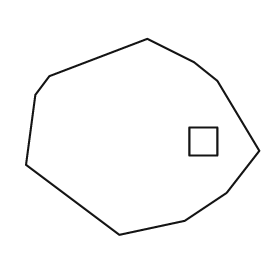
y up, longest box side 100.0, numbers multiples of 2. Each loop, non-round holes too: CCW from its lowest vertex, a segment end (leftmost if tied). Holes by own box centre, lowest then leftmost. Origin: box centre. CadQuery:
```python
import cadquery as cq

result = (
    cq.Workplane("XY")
    .moveTo(-10.0, -42.0)
    .lineTo(18.0, -36.0)
    .lineTo(36.0, -24.0)
    .lineTo(50.0, -6.0)
    .lineTo(32.0, 24.0)
    .lineTo(22.0, 32.0)
    .lineTo(2.0, 42.0)
    .lineTo(-40.0, 26.0)
    .lineTo(-46.0, 18.0)
    .lineTo(-50.0, -12.0)
    .close()
    .moveTo(20.0, -8.0)
    .lineTo(32.0, -8.0)
    .lineTo(32.0, 4.0)
    .lineTo(20.0, 4.0)
    .close()
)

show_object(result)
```